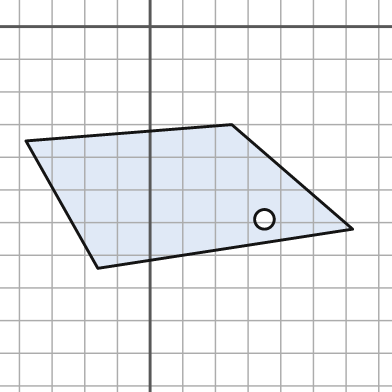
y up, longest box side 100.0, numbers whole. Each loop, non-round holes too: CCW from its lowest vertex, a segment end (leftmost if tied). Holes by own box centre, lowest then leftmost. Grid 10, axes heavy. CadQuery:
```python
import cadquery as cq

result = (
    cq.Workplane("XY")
    .moveTo(-16.0, -74.0)
    .lineTo(62.0, -62.0)
    .lineTo(25.0, -30.0)
    .lineTo(-38.0, -35.0)
    .close()
    .moveTo(35.0, -59.0)
    .circle(3.0)
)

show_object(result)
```